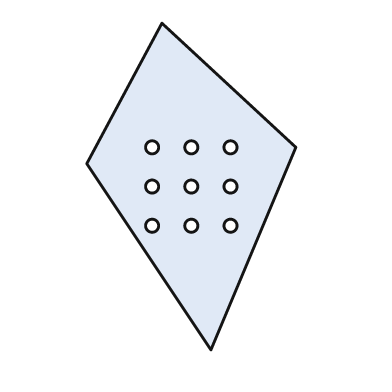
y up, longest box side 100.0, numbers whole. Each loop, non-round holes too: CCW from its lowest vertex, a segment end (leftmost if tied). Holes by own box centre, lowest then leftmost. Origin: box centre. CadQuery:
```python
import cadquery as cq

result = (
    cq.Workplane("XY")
    .moveTo(6.0, -50.0)
    .lineTo(32.0, 12.0)
    .lineTo(-9.0, 50.0)
    .lineTo(-32.0, 7.0)
    .close()
    .moveTo(-12.0, -12.0)
    .circle(2.0)
    .moveTo(0.0, -12.0)
    .circle(2.0)
    .moveTo(12.0, -12.0)
    .circle(2.0)
    .moveTo(-12.0, 0.0)
    .circle(2.0)
    .moveTo(0.0, 0.0)
    .circle(2.0)
    .moveTo(12.0, 0.0)
    .circle(2.0)
    .moveTo(-12.0, 12.0)
    .circle(2.0)
    .moveTo(0.0, 12.0)
    .circle(2.0)
    .moveTo(12.0, 12.0)
    .circle(2.0)
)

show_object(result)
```